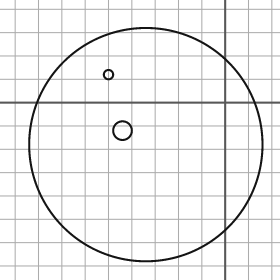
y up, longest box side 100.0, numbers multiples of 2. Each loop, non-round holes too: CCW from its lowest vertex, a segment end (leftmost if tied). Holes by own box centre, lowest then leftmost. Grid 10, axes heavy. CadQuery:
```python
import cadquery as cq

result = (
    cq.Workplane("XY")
    .moveTo(-34.0, -18.0)
    .circle(50.0)
    .moveTo(-44.0, -12.0)
    .circle(4.0)
    .moveTo(-50.0, 12.0)
    .circle(2.0)
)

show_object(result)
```